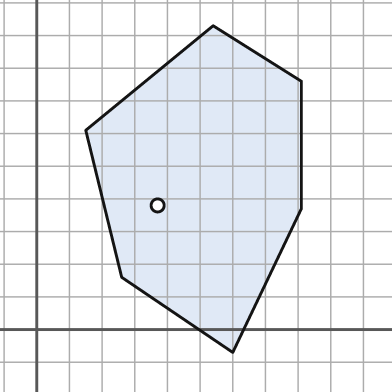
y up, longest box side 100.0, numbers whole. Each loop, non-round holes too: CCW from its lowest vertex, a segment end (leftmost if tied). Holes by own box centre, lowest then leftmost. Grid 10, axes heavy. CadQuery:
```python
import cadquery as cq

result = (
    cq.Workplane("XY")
    .moveTo(60.0, -7.0)
    .lineTo(81.0, 37.0)
    .lineTo(81.0, 76.0)
    .lineTo(54.0, 93.0)
    .lineTo(15.0, 61.0)
    .lineTo(26.0, 16.0)
    .close()
    .moveTo(37.0, 38.0)
    .circle(2.0)
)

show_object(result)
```